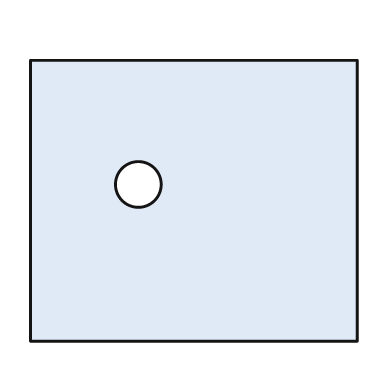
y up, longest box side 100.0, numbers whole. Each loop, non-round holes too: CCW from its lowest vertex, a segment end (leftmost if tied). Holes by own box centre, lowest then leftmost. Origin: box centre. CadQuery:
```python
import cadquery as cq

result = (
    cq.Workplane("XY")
    .moveTo(-50.0, -43.0)
    .lineTo(50.0, -43.0)
    .lineTo(50.0, 43.0)
    .lineTo(-50.0, 43.0)
    .close()
    .moveTo(-17.0, 5.0)
    .circle(7.0)
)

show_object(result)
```